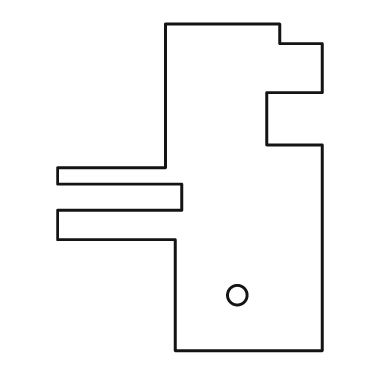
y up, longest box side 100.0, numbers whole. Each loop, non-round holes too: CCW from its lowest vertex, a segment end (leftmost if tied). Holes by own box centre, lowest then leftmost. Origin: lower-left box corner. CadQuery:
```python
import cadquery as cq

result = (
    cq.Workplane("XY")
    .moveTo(36.0, 0.0)
    .lineTo(81.0, 0.0)
    .lineTo(81.0, 63.0)
    .lineTo(64.0, 63.0)
    .lineTo(64.0, 79.0)
    .lineTo(81.0, 79.0)
    .lineTo(81.0, 94.0)
    .lineTo(68.0, 94.0)
    .lineTo(68.0, 100.0)
    .lineTo(33.0, 100.0)
    .lineTo(33.0, 56.0)
    .lineTo(0.0, 56.0)
    .lineTo(0.0, 51.0)
    .lineTo(38.0, 51.0)
    .lineTo(38.0, 43.0)
    .lineTo(0.0, 43.0)
    .lineTo(0.0, 34.0)
    .lineTo(36.0, 34.0)
    .close()
    .moveTo(55.0, 17.0)
    .circle(3.0)
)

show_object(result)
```